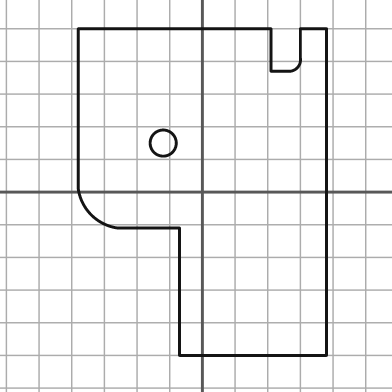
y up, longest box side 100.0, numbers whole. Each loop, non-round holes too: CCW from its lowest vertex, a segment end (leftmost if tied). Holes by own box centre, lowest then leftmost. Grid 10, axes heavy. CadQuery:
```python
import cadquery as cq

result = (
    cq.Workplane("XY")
    .moveTo(-7.0, -50.0)
    .lineTo(38.0, -50.0)
    .lineTo(38.0, 50.0)
    .lineTo(30.0, 50.0)
    .lineTo(30.0, 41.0)
    .threePointArc((29.0, 38.0), (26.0, 37.0))
    .lineTo(21.0, 37.0)
    .lineTo(21.0, 50.0)
    .lineTo(-38.0, 50.0)
    .lineTo(-38.0, 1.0)
    .threePointArc((-34.0, -7.0), (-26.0, -11.0))
    .lineTo(-7.0, -11.0)
    .close()
    .moveTo(-12.0, 15.0)
    .circle(4.0)
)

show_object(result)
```